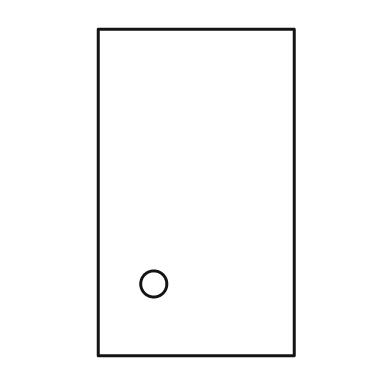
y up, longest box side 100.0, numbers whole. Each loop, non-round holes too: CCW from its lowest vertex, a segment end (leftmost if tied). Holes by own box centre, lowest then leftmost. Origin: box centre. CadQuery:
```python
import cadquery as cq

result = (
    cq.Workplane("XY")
    .moveTo(-30.0, -50.0)
    .lineTo(30.0, -50.0)
    .lineTo(30.0, 50.0)
    .lineTo(-30.0, 50.0)
    .close()
    .moveTo(-13.0, -28.0)
    .circle(4.0)
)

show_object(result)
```